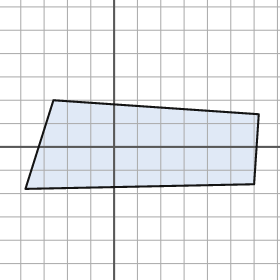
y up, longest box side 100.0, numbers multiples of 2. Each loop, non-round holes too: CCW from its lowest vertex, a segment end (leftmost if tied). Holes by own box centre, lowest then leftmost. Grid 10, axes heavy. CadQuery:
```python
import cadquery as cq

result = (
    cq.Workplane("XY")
    .moveTo(-38.0, -18.0)
    .lineTo(60.0, -16.0)
    .lineTo(62.0, 14.0)
    .lineTo(-26.0, 20.0)
    .close()
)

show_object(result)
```